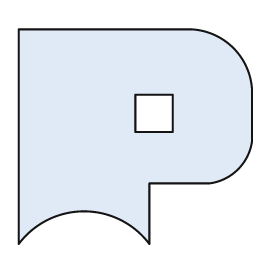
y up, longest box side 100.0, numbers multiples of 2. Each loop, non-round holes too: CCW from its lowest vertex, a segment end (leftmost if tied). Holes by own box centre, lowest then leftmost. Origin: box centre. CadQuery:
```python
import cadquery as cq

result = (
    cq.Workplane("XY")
    .moveTo(-50.0, -46.0)
    .threePointArc((-22.0, -32.0), (6.0, -46.0))
    .lineTo(6.0, -20.0)
    .lineTo(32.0, -20.0)
    .threePointArc((44.0, -14.0), (50.0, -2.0))
    .lineTo(50.0, 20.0)
    .threePointArc((42.0, 38.0), (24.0, 46.0))
    .lineTo(-50.0, 46.0)
    .close()
    .moveTo(0.0, 2.0)
    .lineTo(16.0, 2.0)
    .lineTo(16.0, 18.0)
    .lineTo(0.0, 18.0)
    .close()
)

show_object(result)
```